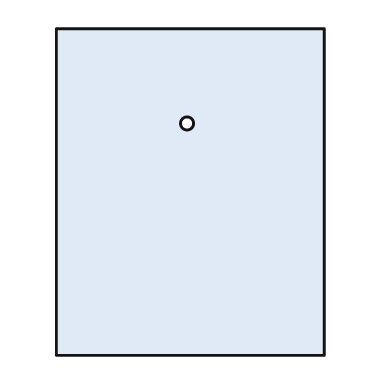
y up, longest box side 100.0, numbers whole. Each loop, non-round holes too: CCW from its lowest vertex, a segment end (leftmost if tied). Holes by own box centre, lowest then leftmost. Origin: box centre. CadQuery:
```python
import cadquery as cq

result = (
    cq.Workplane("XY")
    .moveTo(-41.0, -50.0)
    .lineTo(41.0, -50.0)
    .lineTo(41.0, 50.0)
    .lineTo(-41.0, 50.0)
    .close()
    .moveTo(-1.0, 21.0)
    .circle(2.0)
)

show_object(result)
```